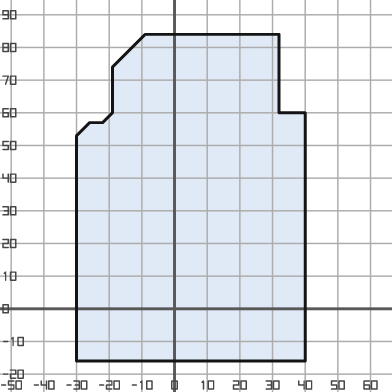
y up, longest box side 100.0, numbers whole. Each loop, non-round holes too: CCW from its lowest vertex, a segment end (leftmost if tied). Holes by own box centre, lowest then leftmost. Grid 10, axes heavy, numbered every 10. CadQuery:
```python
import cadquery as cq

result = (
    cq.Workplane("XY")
    .moveTo(-30.0, -16.0)
    .lineTo(40.0, -16.0)
    .lineTo(40.0, 60.0)
    .lineTo(32.0, 60.0)
    .lineTo(32.0, 84.0)
    .lineTo(-9.0, 84.0)
    .lineTo(-19.0, 74.0)
    .lineTo(-19.0, 60.0)
    .lineTo(-22.0, 57.0)
    .lineTo(-26.0, 57.0)
    .lineTo(-30.0, 53.0)
    .close()
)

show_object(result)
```